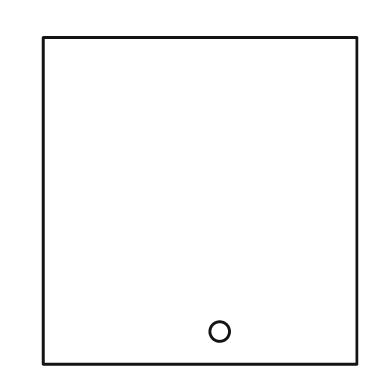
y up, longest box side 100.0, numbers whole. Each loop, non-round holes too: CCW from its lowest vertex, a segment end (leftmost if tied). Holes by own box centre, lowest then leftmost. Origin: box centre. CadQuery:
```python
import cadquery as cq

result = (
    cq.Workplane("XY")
    .moveTo(-48.0, -50.0)
    .lineTo(48.0, -50.0)
    .lineTo(48.0, 50.0)
    .lineTo(-48.0, 50.0)
    .close()
    .moveTo(6.0, -40.0)
    .circle(3.0)
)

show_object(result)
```